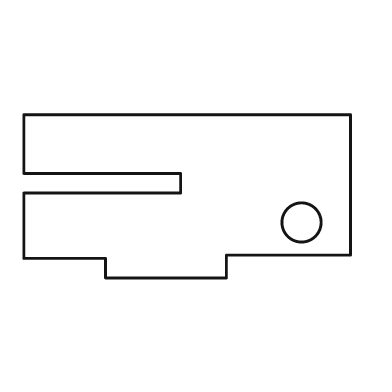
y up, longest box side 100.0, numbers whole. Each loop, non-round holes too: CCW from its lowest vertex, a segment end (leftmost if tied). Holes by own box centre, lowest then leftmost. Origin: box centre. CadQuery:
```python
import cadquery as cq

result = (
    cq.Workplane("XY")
    .moveTo(-25.0, -25.0)
    .lineTo(12.0, -25.0)
    .lineTo(12.0, -18.0)
    .lineTo(50.0, -18.0)
    .lineTo(50.0, 25.0)
    .lineTo(-50.0, 25.0)
    .lineTo(-50.0, 7.0)
    .lineTo(-2.0, 7.0)
    .lineTo(-2.0, 1.0)
    .lineTo(-50.0, 1.0)
    .lineTo(-50.0, -19.0)
    .lineTo(-25.0, -19.0)
    .close()
    .moveTo(35.0, -8.0)
    .circle(6.0)
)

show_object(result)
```